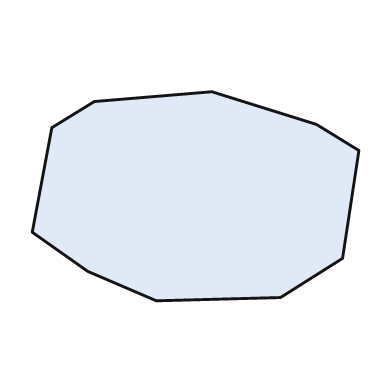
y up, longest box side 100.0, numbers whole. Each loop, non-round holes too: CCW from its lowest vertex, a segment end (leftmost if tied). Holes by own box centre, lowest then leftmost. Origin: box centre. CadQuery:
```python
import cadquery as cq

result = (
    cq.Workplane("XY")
    .moveTo(-12.0, -32.0)
    .lineTo(26.0, -31.0)
    .lineTo(45.0, -19.0)
    .lineTo(50.0, 14.0)
    .lineTo(37.0, 22.0)
    .lineTo(5.0, 32.0)
    .lineTo(-31.0, 29.0)
    .lineTo(-44.0, 21.0)
    .lineTo(-50.0, -11.0)
    .lineTo(-33.0, -23.0)
    .close()
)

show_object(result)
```